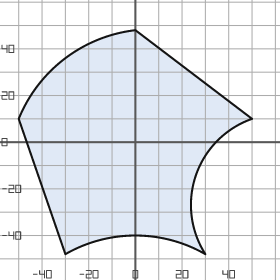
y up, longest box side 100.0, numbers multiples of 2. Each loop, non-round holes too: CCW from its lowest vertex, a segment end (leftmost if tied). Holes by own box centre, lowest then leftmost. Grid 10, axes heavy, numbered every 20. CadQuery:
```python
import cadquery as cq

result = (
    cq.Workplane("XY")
    .moveTo(-30.0, -48.0)
    .threePointArc((0.0, -40.0), (30.0, -48.0))
    .threePointArc((26.0, -14.0), (50.0, 10.0))
    .lineTo(0.0, 48.0)
    .threePointArc((-30.0, 36.0), (-50.0, 10.0))
    .close()
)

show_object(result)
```